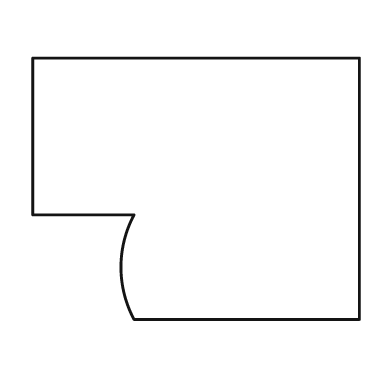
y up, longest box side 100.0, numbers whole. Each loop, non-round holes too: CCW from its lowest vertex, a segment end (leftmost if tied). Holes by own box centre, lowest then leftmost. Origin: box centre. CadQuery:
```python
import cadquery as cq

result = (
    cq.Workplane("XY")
    .moveTo(-19.0, -40.0)
    .lineTo(50.0, -40.0)
    .lineTo(50.0, 40.0)
    .lineTo(-50.0, 40.0)
    .lineTo(-50.0, -8.0)
    .lineTo(-19.0, -8.0)
    .threePointArc((-23.0, -24.0), (-19.0, -40.0))
    .close()
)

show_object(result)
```